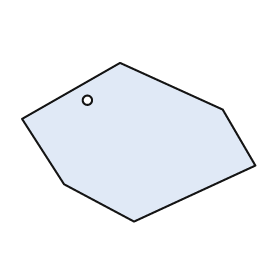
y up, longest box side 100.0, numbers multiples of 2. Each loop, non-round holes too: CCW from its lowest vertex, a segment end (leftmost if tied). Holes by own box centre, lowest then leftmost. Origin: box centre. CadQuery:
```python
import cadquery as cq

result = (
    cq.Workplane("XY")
    .moveTo(-2.0, -34.0)
    .lineTo(50.0, -10.0)
    .lineTo(36.0, 14.0)
    .lineTo(-8.0, 34.0)
    .lineTo(-50.0, 10.0)
    .lineTo(-32.0, -18.0)
    .close()
    .moveTo(-22.0, 18.0)
    .circle(2.0)
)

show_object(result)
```